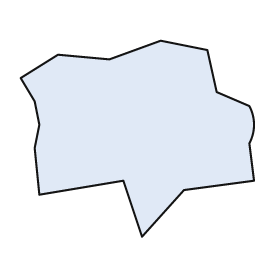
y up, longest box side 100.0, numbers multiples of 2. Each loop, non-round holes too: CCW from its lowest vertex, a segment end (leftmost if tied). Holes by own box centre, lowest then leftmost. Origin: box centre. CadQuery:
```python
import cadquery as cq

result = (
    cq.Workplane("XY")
    .moveTo(2.0, -42.0)
    .lineTo(20.0, -22.0)
    .lineTo(50.0, -18.0)
    .lineTo(48.0, -2.0)
    .threePointArc((50.0, 6.0), (48.0, 14.0))
    .lineTo(34.0, 20.0)
    .lineTo(30.0, 38.0)
    .lineTo(10.0, 42.0)
    .lineTo(-12.0, 34.0)
    .lineTo(-34.0, 36.0)
    .lineTo(-50.0, 26.0)
    .lineTo(-44.0, 16.0)
    .lineTo(-42.0, 6.0)
    .lineTo(-44.0, -4.0)
    .lineTo(-42.0, -24.0)
    .lineTo(-6.0, -18.0)
    .close()
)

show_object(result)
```